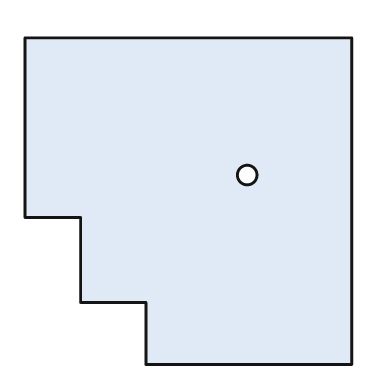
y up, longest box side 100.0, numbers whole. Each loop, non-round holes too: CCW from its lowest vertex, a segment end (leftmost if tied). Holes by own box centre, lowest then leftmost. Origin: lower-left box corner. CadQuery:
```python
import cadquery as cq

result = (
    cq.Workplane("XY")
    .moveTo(37.0, 0.0)
    .lineTo(100.0, 0.0)
    .lineTo(100.0, 100.0)
    .lineTo(0.0, 100.0)
    .lineTo(0.0, 45.0)
    .lineTo(17.0, 45.0)
    .lineTo(17.0, 19.0)
    .lineTo(37.0, 19.0)
    .close()
    .moveTo(68.0, 58.0)
    .circle(3.0)
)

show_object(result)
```